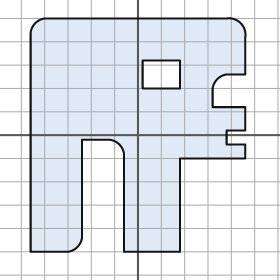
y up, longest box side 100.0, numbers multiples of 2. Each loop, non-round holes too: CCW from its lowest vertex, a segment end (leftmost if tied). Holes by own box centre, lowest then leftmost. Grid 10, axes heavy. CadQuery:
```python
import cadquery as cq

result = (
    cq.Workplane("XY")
    .moveTo(-46.0, -50.0)
    .lineTo(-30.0, -50.0)
    .threePointArc((-26.0, -48.0), (-24.0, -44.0))
    .lineTo(-24.0, -2.0)
    .lineTo(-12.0, -2.0)
    .threePointArc((-8.0, -4.0), (-6.0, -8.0))
    .lineTo(-6.0, -50.0)
    .lineTo(18.0, -50.0)
    .lineTo(18.0, -10.0)
    .lineTo(46.0, -10.0)
    .lineTo(46.0, -4.0)
    .lineTo(38.0, -4.0)
    .lineTo(38.0, 2.0)
    .lineTo(46.0, 2.0)
    .lineTo(46.0, 12.0)
    .lineTo(32.0, 12.0)
    .lineTo(32.0, 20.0)
    .threePointArc((34.0, 24.0), (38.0, 26.0))
    .lineTo(46.0, 26.0)
    .lineTo(46.0, 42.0)
    .threePointArc((44.0, 48.0), (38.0, 50.0))
    .lineTo(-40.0, 50.0)
    .threePointArc((-44.0, 48.0), (-46.0, 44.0))
    .close()
    .moveTo(2.0, 20.0)
    .lineTo(18.0, 20.0)
    .lineTo(18.0, 32.0)
    .lineTo(2.0, 32.0)
    .close()
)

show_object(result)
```